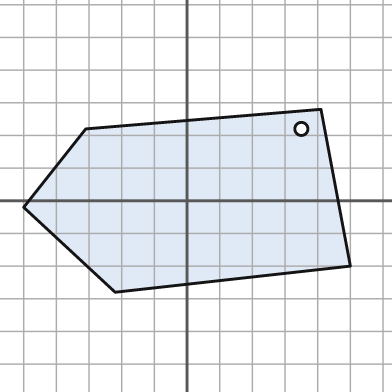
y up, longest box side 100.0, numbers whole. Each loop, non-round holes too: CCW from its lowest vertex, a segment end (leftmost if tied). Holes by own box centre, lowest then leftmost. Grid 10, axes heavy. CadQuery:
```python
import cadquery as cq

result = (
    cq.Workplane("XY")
    .moveTo(-22.0, -28.0)
    .lineTo(50.0, -20.0)
    .lineTo(41.0, 28.0)
    .lineTo(-31.0, 22.0)
    .lineTo(-50.0, -2.0)
    .close()
    .moveTo(35.0, 22.0)
    .circle(2.0)
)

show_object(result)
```